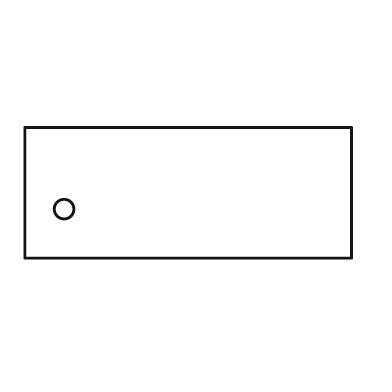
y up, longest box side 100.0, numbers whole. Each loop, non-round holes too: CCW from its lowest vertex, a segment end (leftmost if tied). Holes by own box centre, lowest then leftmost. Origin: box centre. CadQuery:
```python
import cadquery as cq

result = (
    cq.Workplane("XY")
    .moveTo(-50.0, -20.0)
    .lineTo(50.0, -20.0)
    .lineTo(50.0, 20.0)
    .lineTo(-50.0, 20.0)
    .close()
    .moveTo(-38.0, -5.0)
    .circle(3.0)
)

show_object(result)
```